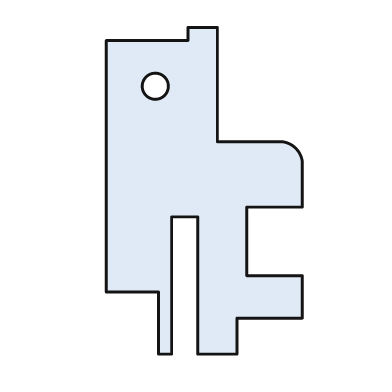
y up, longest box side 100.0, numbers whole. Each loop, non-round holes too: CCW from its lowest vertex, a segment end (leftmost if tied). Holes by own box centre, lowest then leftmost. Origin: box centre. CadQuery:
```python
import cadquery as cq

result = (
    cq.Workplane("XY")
    .moveTo(-14.0, -50.0)
    .lineTo(-10.0, -50.0)
    .lineTo(-10.0, -8.0)
    .lineTo(-2.0, -8.0)
    .lineTo(-2.0, -50.0)
    .lineTo(10.0, -50.0)
    .lineTo(10.0, -39.0)
    .lineTo(30.0, -39.0)
    .lineTo(30.0, -26.0)
    .lineTo(13.0, -26.0)
    .lineTo(13.0, -5.0)
    .lineTo(30.0, -5.0)
    .lineTo(30.0, 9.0)
    .threePointArc((28.0, 13.0), (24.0, 15.0))
    .lineTo(4.0, 15.0)
    .lineTo(4.0, 50.0)
    .lineTo(-5.0, 50.0)
    .lineTo(-5.0, 46.0)
    .lineTo(-30.0, 46.0)
    .lineTo(-30.0, -31.0)
    .lineTo(-14.0, -31.0)
    .close()
    .moveTo(-15.0, 32.0)
    .circle(4.0)
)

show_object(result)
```